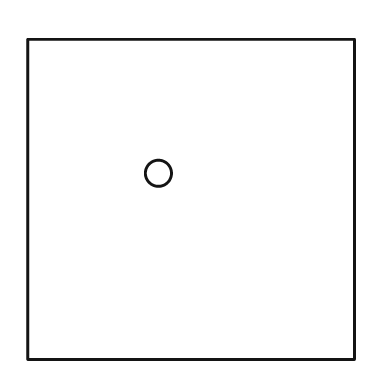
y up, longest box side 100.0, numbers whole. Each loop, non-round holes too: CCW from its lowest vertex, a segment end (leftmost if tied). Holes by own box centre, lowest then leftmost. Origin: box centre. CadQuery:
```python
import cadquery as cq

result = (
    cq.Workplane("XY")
    .moveTo(-50.0, -49.0)
    .lineTo(50.0, -49.0)
    .lineTo(50.0, 49.0)
    .lineTo(-50.0, 49.0)
    .close()
    .moveTo(-10.0, 8.0)
    .circle(4.0)
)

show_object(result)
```